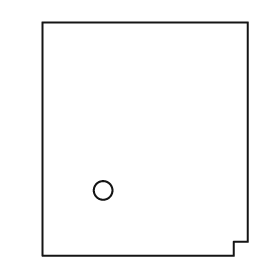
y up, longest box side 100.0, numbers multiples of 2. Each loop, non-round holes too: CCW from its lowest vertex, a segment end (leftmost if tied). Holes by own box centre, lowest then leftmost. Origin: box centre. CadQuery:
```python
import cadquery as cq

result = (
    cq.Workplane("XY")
    .moveTo(-44.0, -50.0)
    .lineTo(38.0, -50.0)
    .lineTo(38.0, -44.0)
    .lineTo(44.0, -44.0)
    .lineTo(44.0, 50.0)
    .lineTo(-44.0, 50.0)
    .close()
    .moveTo(-18.0, -22.0)
    .circle(4.0)
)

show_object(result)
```